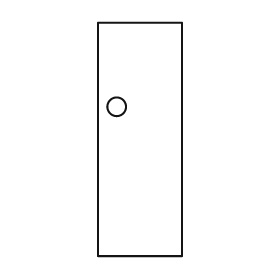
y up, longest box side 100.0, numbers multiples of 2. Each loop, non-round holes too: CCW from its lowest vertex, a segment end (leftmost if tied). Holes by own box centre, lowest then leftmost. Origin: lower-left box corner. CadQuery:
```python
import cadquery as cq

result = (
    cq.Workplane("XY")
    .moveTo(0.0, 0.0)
    .lineTo(36.0, 0.0)
    .lineTo(36.0, 100.0)
    .lineTo(0.0, 100.0)
    .close()
    .moveTo(8.0, 64.0)
    .circle(4.0)
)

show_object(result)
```